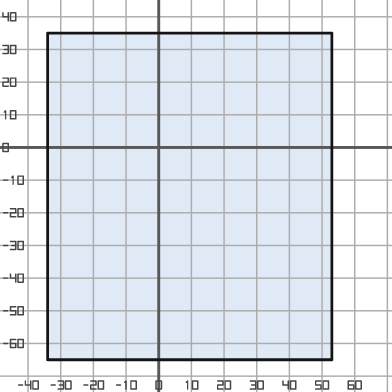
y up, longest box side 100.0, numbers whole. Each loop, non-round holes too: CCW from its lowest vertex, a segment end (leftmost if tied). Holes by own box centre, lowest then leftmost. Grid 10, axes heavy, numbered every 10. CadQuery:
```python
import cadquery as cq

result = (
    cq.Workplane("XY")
    .moveTo(-34.0, -65.0)
    .lineTo(53.0, -65.0)
    .lineTo(53.0, 35.0)
    .lineTo(-34.0, 35.0)
    .close()
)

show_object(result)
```